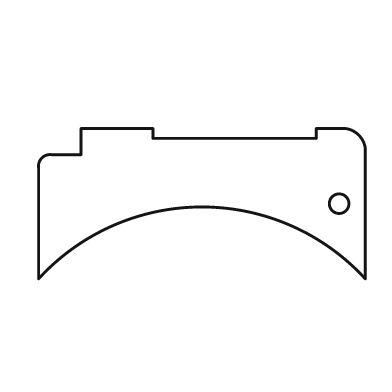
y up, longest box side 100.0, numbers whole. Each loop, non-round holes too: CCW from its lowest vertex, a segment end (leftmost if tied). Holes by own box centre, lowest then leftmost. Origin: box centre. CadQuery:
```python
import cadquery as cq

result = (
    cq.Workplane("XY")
    .moveTo(-50.0, -23.0)
    .threePointArc((0.0, -1.0), (50.0, -23.0))
    .lineTo(50.0, 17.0)
    .threePointArc((48.0, 21.0), (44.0, 23.0))
    .lineTo(35.0, 23.0)
    .lineTo(35.0, 20.0)
    .lineTo(-15.0, 20.0)
    .lineTo(-15.0, 23.0)
    .lineTo(-37.0, 23.0)
    .lineTo(-37.0, 15.0)
    .lineTo(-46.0, 15.0)
    .threePointArc((-49.0, 14.0), (-50.0, 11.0))
    .close()
    .moveTo(42.0, 0.0)
    .circle(3.0)
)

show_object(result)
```